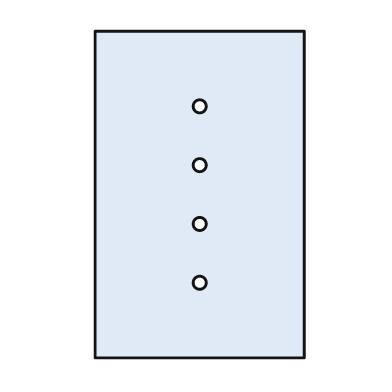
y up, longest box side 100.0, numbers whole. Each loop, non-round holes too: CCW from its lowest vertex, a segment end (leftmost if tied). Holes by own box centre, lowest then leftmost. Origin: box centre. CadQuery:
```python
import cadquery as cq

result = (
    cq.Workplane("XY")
    .moveTo(-32.0, -50.0)
    .lineTo(32.0, -50.0)
    .lineTo(32.0, 50.0)
    .lineTo(-32.0, 50.0)
    .close()
    .moveTo(0.0, -27.0)
    .circle(2.0)
    .moveTo(0.0, -9.0)
    .circle(2.0)
    .moveTo(0.0, 9.0)
    .circle(2.0)
    .moveTo(0.0, 27.0)
    .circle(2.0)
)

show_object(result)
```